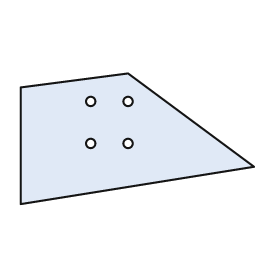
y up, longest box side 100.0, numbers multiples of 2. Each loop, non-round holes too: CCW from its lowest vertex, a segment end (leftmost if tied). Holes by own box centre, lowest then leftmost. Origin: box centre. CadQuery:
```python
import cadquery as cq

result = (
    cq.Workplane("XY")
    .moveTo(-50.0, -28.0)
    .lineTo(50.0, -12.0)
    .lineTo(-4.0, 28.0)
    .lineTo(-50.0, 22.0)
    .close()
    .moveTo(-20.0, -2.0)
    .circle(2.0)
    .moveTo(-4.0, -2.0)
    .circle(2.0)
    .moveTo(-20.0, 16.0)
    .circle(2.0)
    .moveTo(-4.0, 16.0)
    .circle(2.0)
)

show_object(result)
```